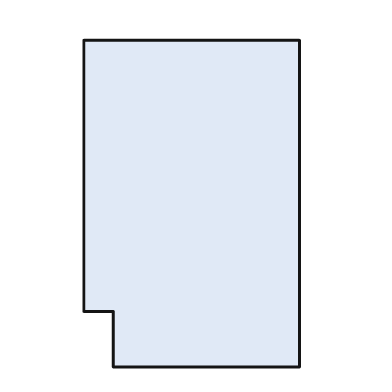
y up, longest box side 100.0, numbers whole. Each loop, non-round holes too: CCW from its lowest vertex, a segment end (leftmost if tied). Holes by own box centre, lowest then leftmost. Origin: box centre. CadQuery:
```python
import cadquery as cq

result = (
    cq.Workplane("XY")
    .moveTo(-24.0, -50.0)
    .lineTo(33.0, -50.0)
    .lineTo(33.0, 50.0)
    .lineTo(-33.0, 50.0)
    .lineTo(-33.0, -33.0)
    .lineTo(-24.0, -33.0)
    .close()
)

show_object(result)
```